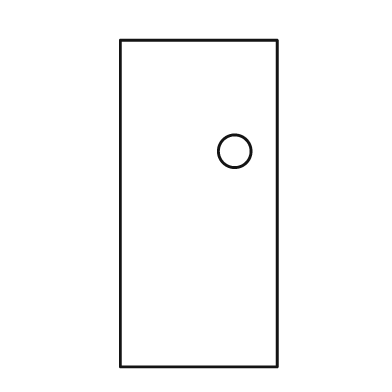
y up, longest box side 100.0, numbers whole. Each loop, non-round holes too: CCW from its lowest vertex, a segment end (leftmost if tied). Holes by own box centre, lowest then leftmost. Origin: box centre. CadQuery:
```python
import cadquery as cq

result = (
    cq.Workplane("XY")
    .moveTo(-24.0, -50.0)
    .lineTo(24.0, -50.0)
    .lineTo(24.0, 50.0)
    .lineTo(-24.0, 50.0)
    .close()
    .moveTo(11.0, 16.0)
    .circle(5.0)
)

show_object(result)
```